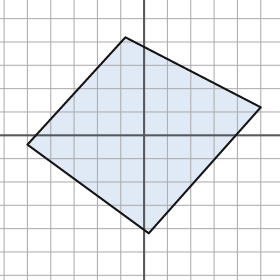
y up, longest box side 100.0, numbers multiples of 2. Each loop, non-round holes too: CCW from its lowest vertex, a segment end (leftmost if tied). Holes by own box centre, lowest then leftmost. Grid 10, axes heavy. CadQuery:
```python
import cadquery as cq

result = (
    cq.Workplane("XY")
    .moveTo(2.0, -42.0)
    .lineTo(50.0, 12.0)
    .lineTo(-8.0, 42.0)
    .lineTo(-50.0, -4.0)
    .close()
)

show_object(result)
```